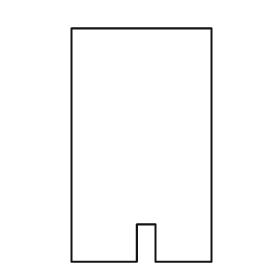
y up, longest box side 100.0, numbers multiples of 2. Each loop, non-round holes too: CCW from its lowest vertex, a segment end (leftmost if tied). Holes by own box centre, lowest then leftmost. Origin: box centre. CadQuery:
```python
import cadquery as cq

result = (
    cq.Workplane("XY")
    .moveTo(-30.0, -50.0)
    .lineTo(-2.0, -50.0)
    .lineTo(-2.0, -34.0)
    .lineTo(6.0, -34.0)
    .lineTo(6.0, -50.0)
    .lineTo(30.0, -50.0)
    .lineTo(30.0, 50.0)
    .lineTo(-30.0, 50.0)
    .close()
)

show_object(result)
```